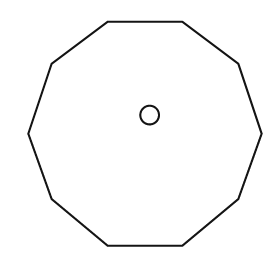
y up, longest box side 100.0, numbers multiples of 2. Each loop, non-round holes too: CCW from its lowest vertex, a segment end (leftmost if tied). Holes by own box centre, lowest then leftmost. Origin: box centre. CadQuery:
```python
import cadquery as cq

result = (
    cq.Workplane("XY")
    .moveTo(-16.0, -48.0)
    .lineTo(16.0, -48.0)
    .lineTo(40.0, -28.0)
    .lineTo(50.0, 0.0)
    .lineTo(40.0, 30.0)
    .lineTo(16.0, 48.0)
    .lineTo(-16.0, 48.0)
    .lineTo(-40.0, 30.0)
    .lineTo(-50.0, 0.0)
    .lineTo(-40.0, -28.0)
    .close()
    .moveTo(2.0, 8.0)
    .circle(4.0)
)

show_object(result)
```